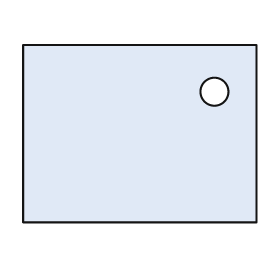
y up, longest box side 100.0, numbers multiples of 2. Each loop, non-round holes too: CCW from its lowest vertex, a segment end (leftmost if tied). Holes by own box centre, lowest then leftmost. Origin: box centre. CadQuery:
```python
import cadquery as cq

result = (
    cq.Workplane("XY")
    .moveTo(-50.0, -38.0)
    .lineTo(50.0, -38.0)
    .lineTo(50.0, 38.0)
    .lineTo(-50.0, 38.0)
    .close()
    .moveTo(32.0, 18.0)
    .circle(6.0)
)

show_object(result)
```